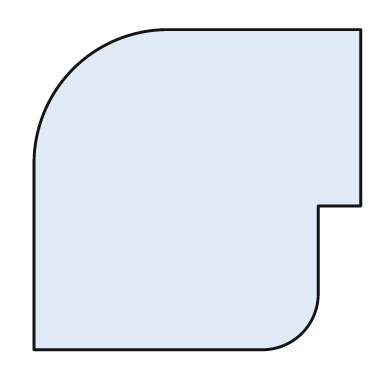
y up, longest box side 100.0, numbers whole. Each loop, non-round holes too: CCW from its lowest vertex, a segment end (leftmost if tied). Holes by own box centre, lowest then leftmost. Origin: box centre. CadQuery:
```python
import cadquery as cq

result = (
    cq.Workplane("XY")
    .moveTo(-50.0, -49.0)
    .lineTo(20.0, -49.0)
    .threePointArc((32.0, -44.0), (37.0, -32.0))
    .lineTo(37.0, -5.0)
    .lineTo(50.0, -5.0)
    .lineTo(50.0, 49.0)
    .lineTo(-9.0, 49.0)
    .threePointArc((-38.0, 37.0), (-50.0, 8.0))
    .close()
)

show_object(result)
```